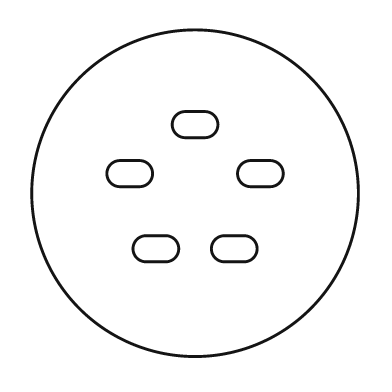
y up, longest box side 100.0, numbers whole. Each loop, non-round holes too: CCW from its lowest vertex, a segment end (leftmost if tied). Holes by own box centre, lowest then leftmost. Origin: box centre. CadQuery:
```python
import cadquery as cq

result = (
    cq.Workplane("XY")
    .moveTo(0.0, 0.0)
    .circle(50.0)
    .moveTo(-15.0, -21.0)
    .lineTo(-9.0, -21.0)
    .threePointArc((-5.0, -17.0), (-9.0, -13.0))
    .lineTo(-15.0, -13.0)
    .threePointArc((-19.0, -17.0), (-15.0, -21.0))
    .close()
    .moveTo(9.0, -21.0)
    .lineTo(15.0, -21.0)
    .threePointArc((19.0, -17.0), (15.0, -13.0))
    .lineTo(9.0, -13.0)
    .threePointArc((5.0, -17.0), (9.0, -21.0))
    .close()
    .moveTo(-23.0, 2.0)
    .lineTo(-17.0, 2.0)
    .threePointArc((-13.0, 6.0), (-17.0, 10.0))
    .lineTo(-23.0, 10.0)
    .threePointArc((-27.0, 6.0), (-23.0, 2.0))
    .close()
    .moveTo(17.0, 2.0)
    .lineTo(23.0, 2.0)
    .threePointArc((27.0, 6.0), (23.0, 10.0))
    .lineTo(17.0, 10.0)
    .threePointArc((13.0, 6.0), (17.0, 2.0))
    .close()
    .moveTo(-3.0, 17.0)
    .lineTo(3.0, 17.0)
    .threePointArc((7.0, 21.0), (3.0, 25.0))
    .lineTo(-3.0, 25.0)
    .threePointArc((-7.0, 21.0), (-3.0, 17.0))
    .close()
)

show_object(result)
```